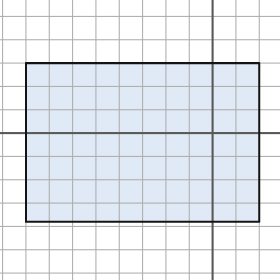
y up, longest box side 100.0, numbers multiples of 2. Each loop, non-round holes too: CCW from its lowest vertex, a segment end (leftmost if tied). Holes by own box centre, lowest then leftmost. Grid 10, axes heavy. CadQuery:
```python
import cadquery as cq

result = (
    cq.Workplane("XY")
    .moveTo(-80.0, -38.0)
    .lineTo(20.0, -38.0)
    .lineTo(20.0, 30.0)
    .lineTo(-80.0, 30.0)
    .close()
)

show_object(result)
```